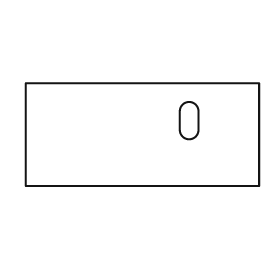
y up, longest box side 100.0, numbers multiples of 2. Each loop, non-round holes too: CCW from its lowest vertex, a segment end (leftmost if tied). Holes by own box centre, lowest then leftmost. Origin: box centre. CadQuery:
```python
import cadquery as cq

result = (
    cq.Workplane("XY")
    .moveTo(-50.0, -22.0)
    .lineTo(50.0, -22.0)
    .lineTo(50.0, 22.0)
    .lineTo(-50.0, 22.0)
    .close()
    .moveTo(16.0, 2.0)
    .threePointArc((20.0, -2.0), (24.0, 2.0))
    .lineTo(24.0, 10.0)
    .threePointArc((20.0, 14.0), (16.0, 10.0))
    .close()
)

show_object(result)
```